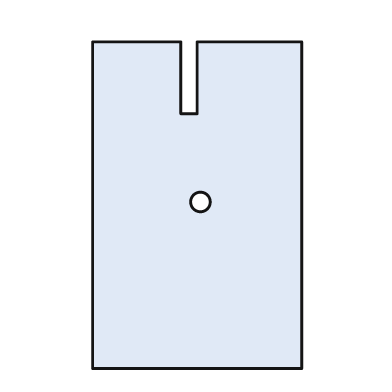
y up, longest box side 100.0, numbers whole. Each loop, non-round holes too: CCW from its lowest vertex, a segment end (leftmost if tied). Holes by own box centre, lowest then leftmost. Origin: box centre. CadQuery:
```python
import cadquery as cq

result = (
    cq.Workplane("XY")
    .moveTo(-32.0, -50.0)
    .lineTo(32.0, -50.0)
    .lineTo(32.0, 50.0)
    .lineTo(0.0, 50.0)
    .lineTo(0.0, 28.0)
    .lineTo(-5.0, 28.0)
    .lineTo(-5.0, 50.0)
    .lineTo(-32.0, 50.0)
    .close()
    .moveTo(1.0, 1.0)
    .circle(3.0)
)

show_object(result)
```